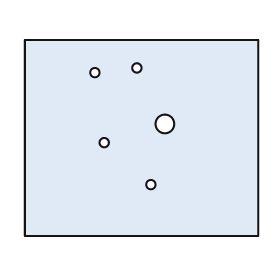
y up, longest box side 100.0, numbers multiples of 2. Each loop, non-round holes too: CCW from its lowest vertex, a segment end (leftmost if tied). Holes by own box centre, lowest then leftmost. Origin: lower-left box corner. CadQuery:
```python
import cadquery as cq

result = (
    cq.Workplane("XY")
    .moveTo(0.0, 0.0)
    .lineTo(100.0, 0.0)
    .lineTo(100.0, 84.0)
    .lineTo(0.0, 84.0)
    .close()
    .moveTo(54.0, 22.0)
    .circle(2.0)
    .moveTo(34.0, 40.0)
    .circle(2.0)
    .moveTo(60.0, 48.0)
    .circle(4.0)
    .moveTo(30.0, 70.0)
    .circle(2.0)
    .moveTo(48.0, 72.0)
    .circle(2.0)
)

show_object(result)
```